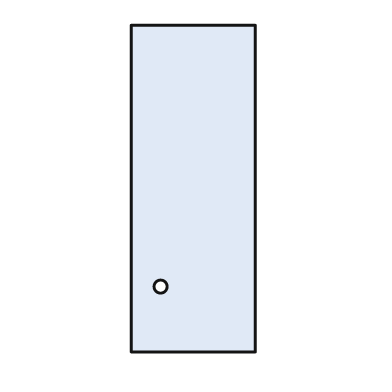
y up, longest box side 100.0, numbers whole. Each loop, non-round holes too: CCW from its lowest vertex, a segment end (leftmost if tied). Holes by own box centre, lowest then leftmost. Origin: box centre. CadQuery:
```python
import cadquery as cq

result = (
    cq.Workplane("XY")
    .moveTo(-19.0, -50.0)
    .lineTo(19.0, -50.0)
    .lineTo(19.0, 50.0)
    .lineTo(-19.0, 50.0)
    .close()
    .moveTo(-10.0, -30.0)
    .circle(2.0)
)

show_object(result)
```